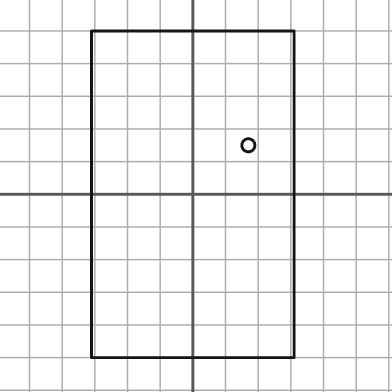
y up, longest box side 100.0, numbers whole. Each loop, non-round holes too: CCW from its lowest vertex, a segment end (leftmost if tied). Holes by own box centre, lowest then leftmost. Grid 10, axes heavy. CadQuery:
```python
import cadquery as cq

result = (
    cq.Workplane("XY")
    .moveTo(-31.0, -50.0)
    .lineTo(31.0, -50.0)
    .lineTo(31.0, 50.0)
    .lineTo(-31.0, 50.0)
    .close()
    .moveTo(17.0, 15.0)
    .circle(2.0)
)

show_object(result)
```